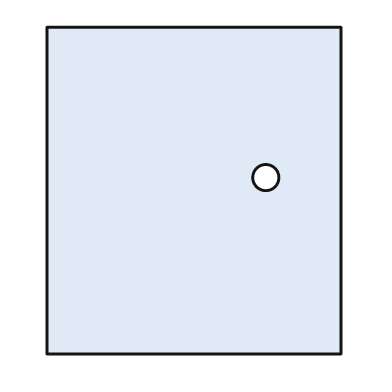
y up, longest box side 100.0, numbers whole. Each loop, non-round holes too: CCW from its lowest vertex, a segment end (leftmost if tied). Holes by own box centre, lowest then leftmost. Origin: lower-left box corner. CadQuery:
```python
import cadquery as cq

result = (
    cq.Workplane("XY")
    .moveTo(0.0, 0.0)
    .lineTo(90.0, 0.0)
    .lineTo(90.0, 100.0)
    .lineTo(0.0, 100.0)
    .close()
    .moveTo(67.0, 54.0)
    .circle(4.0)
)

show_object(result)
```